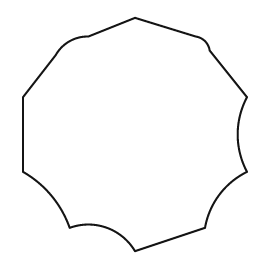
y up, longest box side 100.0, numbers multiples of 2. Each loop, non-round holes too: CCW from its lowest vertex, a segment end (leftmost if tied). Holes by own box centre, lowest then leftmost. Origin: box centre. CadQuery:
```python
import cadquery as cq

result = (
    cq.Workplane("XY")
    .moveTo(0.0, -50.0)
    .lineTo(30.0, -40.0)
    .threePointArc((36.0, -26.0), (48.0, -16.0))
    .threePointArc((44.0, 0.0), (48.0, 16.0))
    .lineTo(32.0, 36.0)
    .threePointArc((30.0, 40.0), (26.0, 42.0))
    .lineTo(0.0, 50.0)
    .lineTo(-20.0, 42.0)
    .threePointArc((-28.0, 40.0), (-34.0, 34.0))
    .lineTo(-48.0, 16.0)
    .lineTo(-48.0, -16.0)
    .threePointArc((-36.0, -26.0), (-28.0, -40.0))
    .threePointArc((-12.0, -40.0), (0.0, -50.0))
    .close()
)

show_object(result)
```